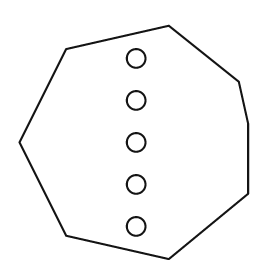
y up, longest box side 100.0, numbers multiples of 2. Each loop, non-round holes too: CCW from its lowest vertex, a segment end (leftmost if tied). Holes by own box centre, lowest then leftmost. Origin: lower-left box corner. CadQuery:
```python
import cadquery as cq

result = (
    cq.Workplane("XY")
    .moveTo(64.0, 0.0)
    .lineTo(98.0, 28.0)
    .lineTo(98.0, 58.0)
    .lineTo(94.0, 76.0)
    .lineTo(64.0, 100.0)
    .lineTo(20.0, 90.0)
    .lineTo(0.0, 50.0)
    .lineTo(20.0, 10.0)
    .close()
    .moveTo(50.0, 14.0)
    .circle(4.0)
    .moveTo(50.0, 32.0)
    .circle(4.0)
    .moveTo(50.0, 50.0)
    .circle(4.0)
    .moveTo(50.0, 68.0)
    .circle(4.0)
    .moveTo(50.0, 86.0)
    .circle(4.0)
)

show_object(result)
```